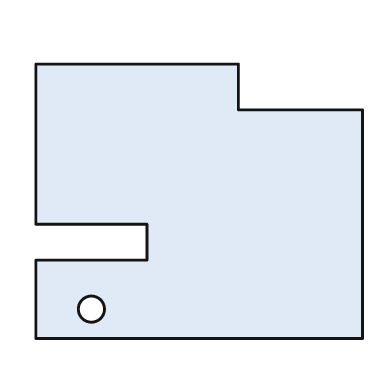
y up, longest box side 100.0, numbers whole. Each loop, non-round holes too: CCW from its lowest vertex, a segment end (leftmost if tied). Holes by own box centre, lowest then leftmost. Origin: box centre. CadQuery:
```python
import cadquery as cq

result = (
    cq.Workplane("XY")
    .moveTo(-50.0, -42.0)
    .lineTo(50.0, -42.0)
    .lineTo(50.0, 28.0)
    .lineTo(12.0, 28.0)
    .lineTo(12.0, 42.0)
    .lineTo(-50.0, 42.0)
    .lineTo(-50.0, -7.0)
    .lineTo(-16.0, -7.0)
    .lineTo(-16.0, -18.0)
    .lineTo(-50.0, -18.0)
    .close()
    .moveTo(-33.0, -33.0)
    .circle(4.0)
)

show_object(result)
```